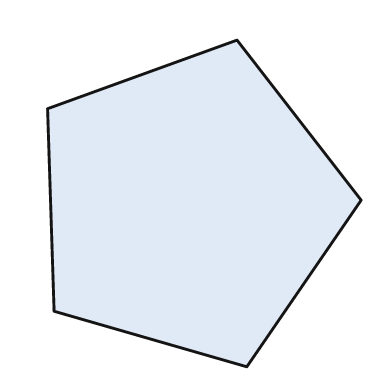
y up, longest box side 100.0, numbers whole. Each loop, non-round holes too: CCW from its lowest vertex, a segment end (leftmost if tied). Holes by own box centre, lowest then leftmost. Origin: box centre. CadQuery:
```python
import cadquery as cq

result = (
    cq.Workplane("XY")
    .moveTo(13.0, -50.0)
    .lineTo(48.0, 1.0)
    .lineTo(10.0, 50.0)
    .lineTo(-48.0, 29.0)
    .lineTo(-46.0, -33.0)
    .close()
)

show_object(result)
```